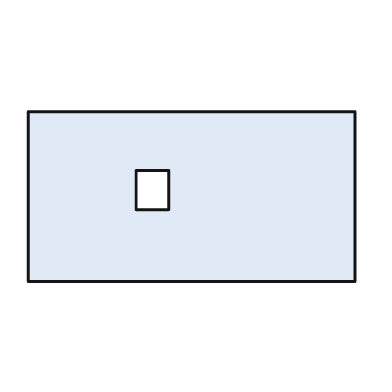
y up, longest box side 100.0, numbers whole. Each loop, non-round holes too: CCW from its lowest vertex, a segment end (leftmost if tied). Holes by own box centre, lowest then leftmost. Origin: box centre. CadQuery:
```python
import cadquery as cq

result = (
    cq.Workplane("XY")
    .moveTo(-50.0, -26.0)
    .lineTo(50.0, -26.0)
    .lineTo(50.0, 26.0)
    .lineTo(-50.0, 26.0)
    .close()
    .moveTo(-17.0, -4.0)
    .lineTo(-7.0, -4.0)
    .lineTo(-7.0, 8.0)
    .lineTo(-17.0, 8.0)
    .close()
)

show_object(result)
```